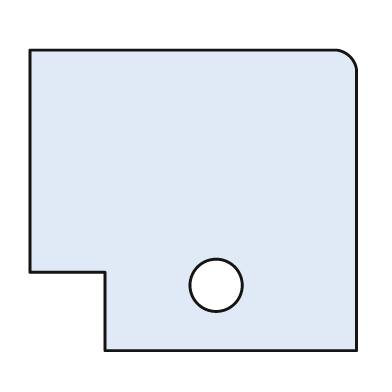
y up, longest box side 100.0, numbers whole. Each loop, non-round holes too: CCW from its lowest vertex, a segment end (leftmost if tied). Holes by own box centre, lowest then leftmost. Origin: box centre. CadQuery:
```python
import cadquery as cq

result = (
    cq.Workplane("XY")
    .moveTo(-27.0, -46.0)
    .lineTo(50.0, -46.0)
    .lineTo(50.0, 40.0)
    .threePointArc((48.0, 44.0), (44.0, 46.0))
    .lineTo(-50.0, 46.0)
    .lineTo(-50.0, -22.0)
    .lineTo(-27.0, -22.0)
    .close()
    .moveTo(7.0, -26.0)
    .circle(8.0)
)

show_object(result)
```